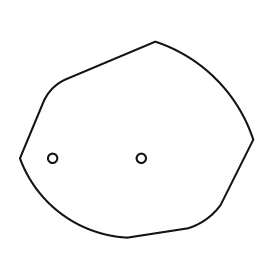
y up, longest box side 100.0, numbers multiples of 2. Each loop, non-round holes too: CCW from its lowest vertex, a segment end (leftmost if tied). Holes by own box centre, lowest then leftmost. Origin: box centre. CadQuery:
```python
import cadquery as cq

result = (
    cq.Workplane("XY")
    .moveTo(-4.0, -42.0)
    .lineTo(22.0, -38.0)
    .threePointArc((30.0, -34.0), (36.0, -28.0))
    .lineTo(50.0, 0.0)
    .threePointArc((34.0, 26.0), (8.0, 42.0))
    .lineTo(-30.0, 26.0)
    .threePointArc((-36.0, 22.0), (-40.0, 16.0))
    .lineTo(-50.0, -8.0)
    .threePointArc((-32.0, -32.0), (-4.0, -42.0))
    .close()
    .moveTo(-36.0, -8.0)
    .circle(2.0)
    .moveTo(2.0, -8.0)
    .circle(2.0)
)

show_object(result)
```